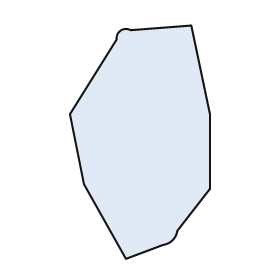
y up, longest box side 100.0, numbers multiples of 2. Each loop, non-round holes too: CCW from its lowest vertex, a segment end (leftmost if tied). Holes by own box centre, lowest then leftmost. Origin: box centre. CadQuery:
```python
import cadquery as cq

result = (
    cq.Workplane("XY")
    .moveTo(-6.0, -50.0)
    .lineTo(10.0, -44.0)
    .threePointArc((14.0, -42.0), (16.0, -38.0))
    .lineTo(30.0, -20.0)
    .lineTo(30.0, 12.0)
    .lineTo(22.0, 50.0)
    .lineTo(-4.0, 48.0)
    .threePointArc((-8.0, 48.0), (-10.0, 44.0))
    .lineTo(-30.0, 12.0)
    .lineTo(-24.0, -18.0)
    .close()
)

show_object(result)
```